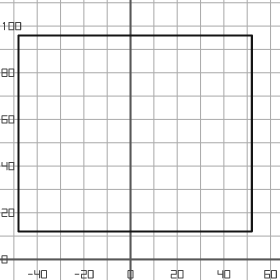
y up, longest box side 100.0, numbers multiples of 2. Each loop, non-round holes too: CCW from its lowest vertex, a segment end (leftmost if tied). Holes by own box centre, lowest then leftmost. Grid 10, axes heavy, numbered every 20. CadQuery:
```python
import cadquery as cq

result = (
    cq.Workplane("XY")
    .moveTo(-48.0, 12.0)
    .lineTo(52.0, 12.0)
    .lineTo(52.0, 96.0)
    .lineTo(-48.0, 96.0)
    .close()
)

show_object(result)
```